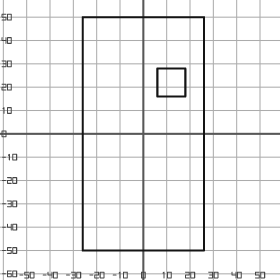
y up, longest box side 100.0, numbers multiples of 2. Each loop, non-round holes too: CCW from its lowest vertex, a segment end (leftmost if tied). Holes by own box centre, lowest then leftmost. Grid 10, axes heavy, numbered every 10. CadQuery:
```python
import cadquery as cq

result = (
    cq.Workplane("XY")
    .moveTo(-26.0, -50.0)
    .lineTo(26.0, -50.0)
    .lineTo(26.0, 50.0)
    .lineTo(-26.0, 50.0)
    .close()
    .moveTo(6.0, 16.0)
    .lineTo(18.0, 16.0)
    .lineTo(18.0, 28.0)
    .lineTo(6.0, 28.0)
    .close()
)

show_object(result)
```